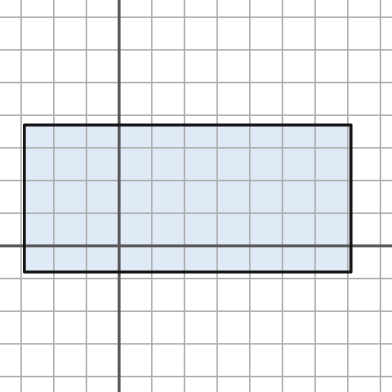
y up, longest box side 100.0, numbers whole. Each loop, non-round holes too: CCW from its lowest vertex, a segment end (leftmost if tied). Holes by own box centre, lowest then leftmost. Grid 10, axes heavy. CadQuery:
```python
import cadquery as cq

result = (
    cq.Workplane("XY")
    .moveTo(-29.0, -8.0)
    .lineTo(71.0, -8.0)
    .lineTo(71.0, 37.0)
    .lineTo(-29.0, 37.0)
    .close()
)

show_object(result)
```